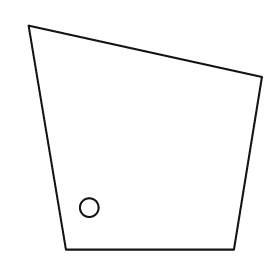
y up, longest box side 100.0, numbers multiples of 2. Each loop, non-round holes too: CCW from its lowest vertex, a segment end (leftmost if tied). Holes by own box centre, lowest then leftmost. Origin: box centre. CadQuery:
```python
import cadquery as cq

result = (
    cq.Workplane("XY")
    .moveTo(-34.0, -48.0)
    .lineTo(38.0, -48.0)
    .lineTo(50.0, 26.0)
    .lineTo(-50.0, 48.0)
    .close()
    .moveTo(-24.0, -30.0)
    .circle(4.0)
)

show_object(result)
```